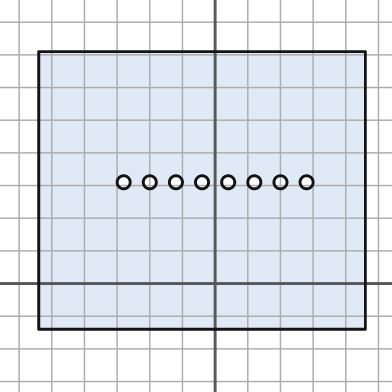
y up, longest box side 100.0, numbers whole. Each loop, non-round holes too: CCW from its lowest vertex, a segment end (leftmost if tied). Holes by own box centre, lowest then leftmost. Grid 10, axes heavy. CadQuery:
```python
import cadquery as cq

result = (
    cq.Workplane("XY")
    .moveTo(-54.0, -14.0)
    .lineTo(46.0, -14.0)
    .lineTo(46.0, 71.0)
    .lineTo(-54.0, 71.0)
    .close()
    .moveTo(-28.0, 31.0)
    .circle(2.0)
    .moveTo(-20.0, 31.0)
    .circle(2.0)
    .moveTo(-12.0, 31.0)
    .circle(2.0)
    .moveTo(-4.0, 31.0)
    .circle(2.0)
    .moveTo(4.0, 31.0)
    .circle(2.0)
    .moveTo(12.0, 31.0)
    .circle(2.0)
    .moveTo(20.0, 31.0)
    .circle(2.0)
    .moveTo(28.0, 31.0)
    .circle(2.0)
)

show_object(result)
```